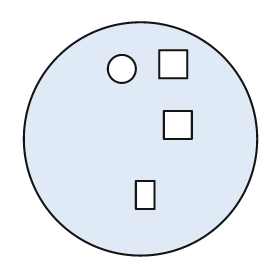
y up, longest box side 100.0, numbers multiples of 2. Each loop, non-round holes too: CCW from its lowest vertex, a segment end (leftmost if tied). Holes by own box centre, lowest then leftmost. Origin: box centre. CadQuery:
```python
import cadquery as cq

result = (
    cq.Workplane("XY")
    .moveTo(0.0, 0.0)
    .circle(50.0)
    .moveTo(-2.0, -30.0)
    .lineTo(6.0, -30.0)
    .lineTo(6.0, -18.0)
    .lineTo(-2.0, -18.0)
    .close()
    .moveTo(10.0, 0.0)
    .lineTo(22.0, 0.0)
    .lineTo(22.0, 12.0)
    .lineTo(10.0, 12.0)
    .close()
    .moveTo(-8.0, 30.0)
    .circle(6.0)
    .moveTo(8.0, 26.0)
    .lineTo(20.0, 26.0)
    .lineTo(20.0, 38.0)
    .lineTo(8.0, 38.0)
    .close()
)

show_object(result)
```